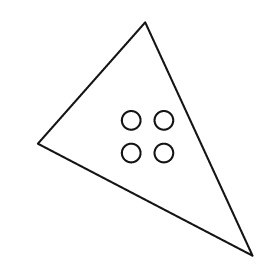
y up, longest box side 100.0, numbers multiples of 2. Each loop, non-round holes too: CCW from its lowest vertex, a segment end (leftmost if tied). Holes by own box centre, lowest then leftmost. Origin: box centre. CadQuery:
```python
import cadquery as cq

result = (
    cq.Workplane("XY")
    .moveTo(46.0, -50.0)
    .lineTo(0.0, 50.0)
    .lineTo(-46.0, -2.0)
    .close()
    .moveTo(-6.0, -6.0)
    .circle(4.0)
    .moveTo(8.0, -6.0)
    .circle(4.0)
    .moveTo(-6.0, 8.0)
    .circle(4.0)
    .moveTo(8.0, 8.0)
    .circle(4.0)
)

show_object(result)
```